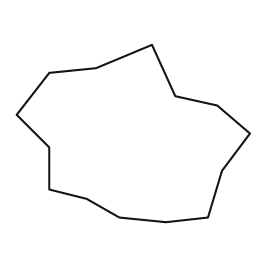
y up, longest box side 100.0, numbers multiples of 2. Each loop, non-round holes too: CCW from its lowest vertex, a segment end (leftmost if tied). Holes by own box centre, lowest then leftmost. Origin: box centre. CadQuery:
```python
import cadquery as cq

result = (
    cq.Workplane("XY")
    .moveTo(14.0, -38.0)
    .lineTo(32.0, -36.0)
    .lineTo(38.0, -16.0)
    .lineTo(50.0, 0.0)
    .lineTo(36.0, 12.0)
    .lineTo(18.0, 16.0)
    .lineTo(8.0, 38.0)
    .lineTo(-16.0, 28.0)
    .lineTo(-36.0, 26.0)
    .lineTo(-50.0, 8.0)
    .lineTo(-36.0, -6.0)
    .lineTo(-36.0, -24.0)
    .lineTo(-20.0, -28.0)
    .lineTo(-6.0, -36.0)
    .close()
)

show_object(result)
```